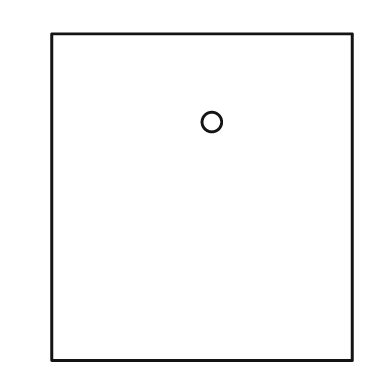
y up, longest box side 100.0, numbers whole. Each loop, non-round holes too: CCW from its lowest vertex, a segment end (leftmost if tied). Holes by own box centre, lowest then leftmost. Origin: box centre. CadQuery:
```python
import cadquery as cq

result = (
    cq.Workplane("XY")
    .moveTo(-46.0, -50.0)
    .lineTo(46.0, -50.0)
    .lineTo(46.0, 50.0)
    .lineTo(-46.0, 50.0)
    .close()
    .moveTo(3.0, 23.0)
    .circle(3.0)
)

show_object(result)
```